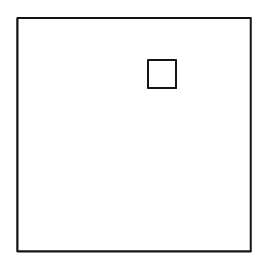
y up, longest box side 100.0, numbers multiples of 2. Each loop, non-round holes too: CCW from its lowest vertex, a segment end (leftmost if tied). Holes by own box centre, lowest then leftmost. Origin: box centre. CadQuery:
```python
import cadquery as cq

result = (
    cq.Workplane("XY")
    .moveTo(-50.0, -50.0)
    .lineTo(50.0, -50.0)
    .lineTo(50.0, 50.0)
    .lineTo(-50.0, 50.0)
    .close()
    .moveTo(6.0, 20.0)
    .lineTo(18.0, 20.0)
    .lineTo(18.0, 32.0)
    .lineTo(6.0, 32.0)
    .close()
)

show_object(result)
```